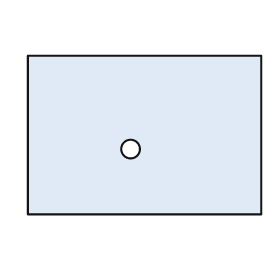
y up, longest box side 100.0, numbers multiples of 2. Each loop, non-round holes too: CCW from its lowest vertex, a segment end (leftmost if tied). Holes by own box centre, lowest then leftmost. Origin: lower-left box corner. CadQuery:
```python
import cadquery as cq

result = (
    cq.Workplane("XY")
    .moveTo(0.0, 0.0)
    .lineTo(100.0, 0.0)
    .lineTo(100.0, 68.0)
    .lineTo(0.0, 68.0)
    .close()
    .moveTo(44.0, 28.0)
    .circle(4.0)
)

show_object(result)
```